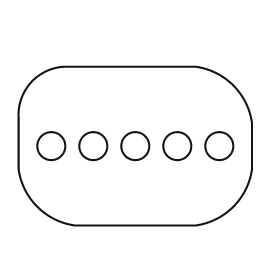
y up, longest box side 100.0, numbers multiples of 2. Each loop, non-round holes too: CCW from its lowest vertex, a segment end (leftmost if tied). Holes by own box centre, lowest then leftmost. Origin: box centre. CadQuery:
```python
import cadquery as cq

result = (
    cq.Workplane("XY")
    .moveTo(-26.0, -34.0)
    .lineTo(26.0, -34.0)
    .threePointArc((42.0, -26.0), (50.0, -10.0))
    .lineTo(50.0, 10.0)
    .threePointArc((42.0, 26.0), (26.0, 34.0))
    .lineTo(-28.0, 34.0)
    .threePointArc((-44.0, 28.0), (-50.0, 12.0))
    .lineTo(-50.0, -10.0)
    .threePointArc((-42.0, -26.0), (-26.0, -34.0))
    .close()
    .moveTo(-36.0, 0.0)
    .circle(6.0)
    .moveTo(-18.0, 0.0)
    .circle(6.0)
    .moveTo(0.0, 0.0)
    .circle(6.0)
    .moveTo(18.0, 0.0)
    .circle(6.0)
    .moveTo(36.0, 0.0)
    .circle(6.0)
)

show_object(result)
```